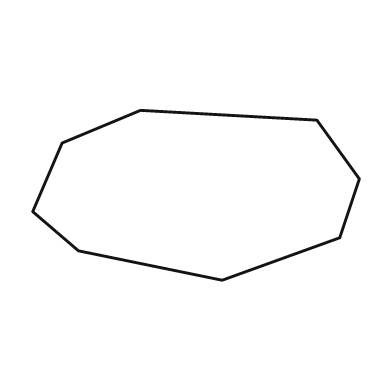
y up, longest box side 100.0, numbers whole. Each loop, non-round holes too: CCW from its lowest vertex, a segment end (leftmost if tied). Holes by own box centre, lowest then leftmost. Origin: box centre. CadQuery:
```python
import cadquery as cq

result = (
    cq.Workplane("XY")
    .moveTo(8.0, -26.0)
    .lineTo(44.0, -13.0)
    .lineTo(50.0, 5.0)
    .lineTo(37.0, 23.0)
    .lineTo(-17.0, 26.0)
    .lineTo(-41.0, 16.0)
    .lineTo(-50.0, -5.0)
    .lineTo(-36.0, -17.0)
    .close()
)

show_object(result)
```